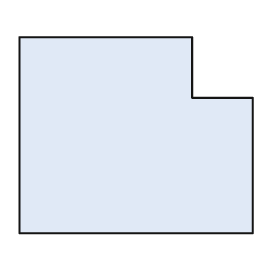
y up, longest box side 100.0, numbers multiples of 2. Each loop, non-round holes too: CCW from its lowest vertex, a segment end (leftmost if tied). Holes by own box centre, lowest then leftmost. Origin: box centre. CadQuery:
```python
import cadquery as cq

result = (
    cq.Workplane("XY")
    .moveTo(-50.0, -42.0)
    .lineTo(50.0, -42.0)
    .lineTo(50.0, 16.0)
    .lineTo(24.0, 16.0)
    .lineTo(24.0, 42.0)
    .lineTo(-50.0, 42.0)
    .close()
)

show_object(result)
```